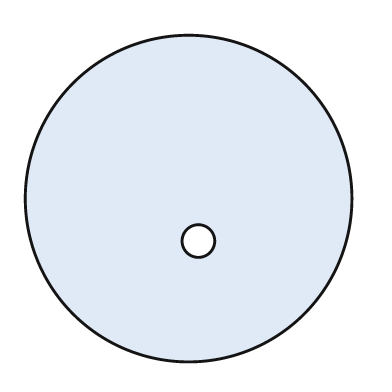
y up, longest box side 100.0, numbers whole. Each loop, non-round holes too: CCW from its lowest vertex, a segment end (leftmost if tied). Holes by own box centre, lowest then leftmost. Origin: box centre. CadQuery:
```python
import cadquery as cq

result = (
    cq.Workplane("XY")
    .moveTo(0.0, 0.0)
    .circle(50.0)
    .moveTo(3.0, -13.0)
    .circle(5.0)
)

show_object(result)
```